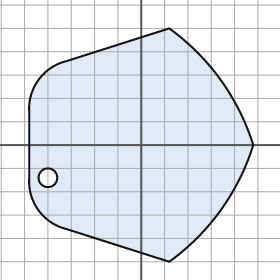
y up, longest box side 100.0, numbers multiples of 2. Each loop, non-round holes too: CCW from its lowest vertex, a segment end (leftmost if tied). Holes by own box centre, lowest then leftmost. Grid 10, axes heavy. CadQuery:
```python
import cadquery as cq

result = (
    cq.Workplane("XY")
    .moveTo(12.0, -50.0)
    .threePointArc((34.0, -28.0), (48.0, 0.0))
    .threePointArc((34.0, 28.0), (12.0, 50.0))
    .lineTo(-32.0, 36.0)
    .threePointArc((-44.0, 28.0), (-48.0, 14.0))
    .lineTo(-48.0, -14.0)
    .threePointArc((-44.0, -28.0), (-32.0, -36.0))
    .close()
    .moveTo(-40.0, -14.0)
    .circle(4.0)
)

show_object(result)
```